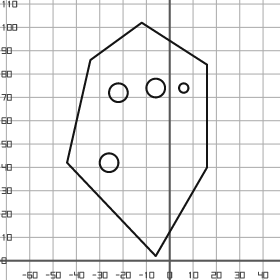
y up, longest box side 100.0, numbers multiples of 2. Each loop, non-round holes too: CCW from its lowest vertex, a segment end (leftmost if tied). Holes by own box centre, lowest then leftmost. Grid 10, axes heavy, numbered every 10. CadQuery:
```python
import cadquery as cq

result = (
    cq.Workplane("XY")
    .moveTo(-6.0, 2.0)
    .lineTo(16.0, 40.0)
    .lineTo(16.0, 84.0)
    .lineTo(-12.0, 102.0)
    .lineTo(-34.0, 86.0)
    .lineTo(-44.0, 42.0)
    .close()
    .moveTo(-26.0, 42.0)
    .circle(4.0)
    .moveTo(-22.0, 72.0)
    .circle(4.0)
    .moveTo(-6.0, 74.0)
    .circle(4.0)
    .moveTo(6.0, 74.0)
    .circle(2.0)
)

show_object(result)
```